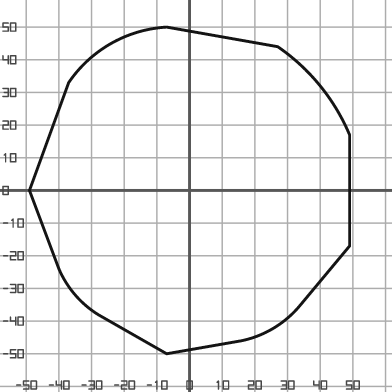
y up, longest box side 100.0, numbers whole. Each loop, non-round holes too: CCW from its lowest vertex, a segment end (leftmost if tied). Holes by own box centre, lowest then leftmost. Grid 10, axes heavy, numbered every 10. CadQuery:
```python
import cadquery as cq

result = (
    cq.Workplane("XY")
    .moveTo(-7.0, -50.0)
    .lineTo(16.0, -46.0)
    .threePointArc((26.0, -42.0), (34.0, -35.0))
    .lineTo(49.0, -17.0)
    .lineTo(49.0, 17.0)
    .threePointArc((40.0, 32.0), (27.0, 44.0))
    .lineTo(-7.0, 50.0)
    .threePointArc((-24.0, 45.0), (-37.0, 33.0))
    .lineTo(-49.0, 0.0)
    .lineTo(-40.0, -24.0)
    .threePointArc((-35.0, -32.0), (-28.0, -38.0))
    .close()
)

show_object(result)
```